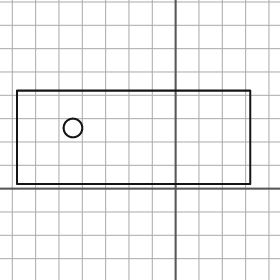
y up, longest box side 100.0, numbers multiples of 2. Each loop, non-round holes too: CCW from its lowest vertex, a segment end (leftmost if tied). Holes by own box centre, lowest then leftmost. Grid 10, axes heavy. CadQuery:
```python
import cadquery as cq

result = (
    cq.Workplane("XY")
    .moveTo(-68.0, 2.0)
    .lineTo(32.0, 2.0)
    .lineTo(32.0, 42.0)
    .lineTo(-68.0, 42.0)
    .close()
    .moveTo(-44.0, 26.0)
    .circle(4.0)
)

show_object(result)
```